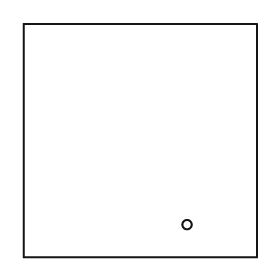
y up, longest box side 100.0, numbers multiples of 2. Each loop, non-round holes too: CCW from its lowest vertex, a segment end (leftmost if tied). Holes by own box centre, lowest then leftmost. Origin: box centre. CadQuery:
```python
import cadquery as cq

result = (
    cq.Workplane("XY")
    .moveTo(-50.0, -50.0)
    .lineTo(50.0, -50.0)
    .lineTo(50.0, 50.0)
    .lineTo(-50.0, 50.0)
    .close()
    .moveTo(20.0, -36.0)
    .circle(2.0)
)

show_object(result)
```